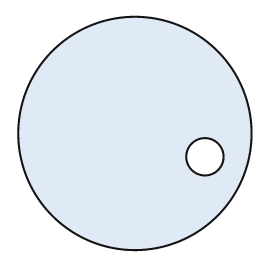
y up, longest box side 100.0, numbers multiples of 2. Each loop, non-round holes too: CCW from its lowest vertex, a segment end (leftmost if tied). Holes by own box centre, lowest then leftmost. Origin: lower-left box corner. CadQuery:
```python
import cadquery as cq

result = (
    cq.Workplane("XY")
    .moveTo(50.0, 50.0)
    .circle(50.0)
    .moveTo(80.0, 40.0)
    .circle(8.0)
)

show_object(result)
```